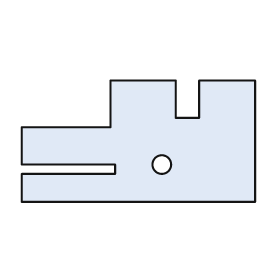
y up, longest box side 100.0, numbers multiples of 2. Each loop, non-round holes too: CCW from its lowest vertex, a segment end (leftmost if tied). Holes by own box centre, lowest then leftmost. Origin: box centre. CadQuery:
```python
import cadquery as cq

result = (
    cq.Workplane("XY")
    .moveTo(-50.0, -26.0)
    .lineTo(50.0, -26.0)
    .lineTo(50.0, 26.0)
    .lineTo(26.0, 26.0)
    .lineTo(26.0, 10.0)
    .lineTo(16.0, 10.0)
    .lineTo(16.0, 26.0)
    .lineTo(-12.0, 26.0)
    .lineTo(-12.0, 6.0)
    .lineTo(-50.0, 6.0)
    .lineTo(-50.0, -10.0)
    .lineTo(-10.0, -10.0)
    .lineTo(-10.0, -14.0)
    .lineTo(-50.0, -14.0)
    .close()
    .moveTo(10.0, -10.0)
    .circle(4.0)
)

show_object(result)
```